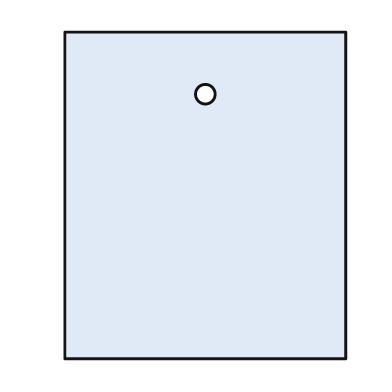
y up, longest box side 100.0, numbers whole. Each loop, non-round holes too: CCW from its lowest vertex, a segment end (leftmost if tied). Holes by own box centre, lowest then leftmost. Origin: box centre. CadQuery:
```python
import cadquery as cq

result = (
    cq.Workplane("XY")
    .moveTo(-43.0, -50.0)
    .lineTo(43.0, -50.0)
    .lineTo(43.0, 50.0)
    .lineTo(-43.0, 50.0)
    .close()
    .moveTo(0.0, 31.0)
    .circle(3.0)
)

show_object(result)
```